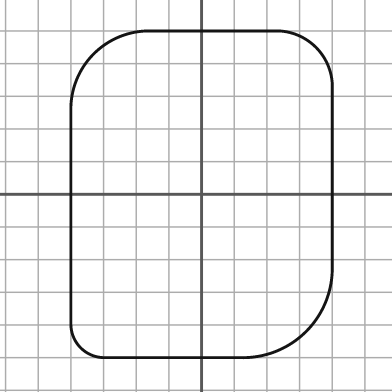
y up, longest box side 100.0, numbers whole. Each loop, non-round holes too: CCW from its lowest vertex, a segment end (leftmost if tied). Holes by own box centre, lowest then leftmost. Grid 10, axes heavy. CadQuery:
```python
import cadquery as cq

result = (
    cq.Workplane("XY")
    .moveTo(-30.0, -50.0)
    .lineTo(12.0, -50.0)
    .threePointArc((32.0, -42.0), (40.0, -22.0))
    .lineTo(40.0, 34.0)
    .threePointArc((35.0, 45.0), (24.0, 50.0))
    .lineTo(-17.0, 50.0)
    .threePointArc((-33.0, 43.0), (-40.0, 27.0))
    .lineTo(-40.0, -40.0)
    .threePointArc((-37.0, -47.0), (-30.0, -50.0))
    .close()
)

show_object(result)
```